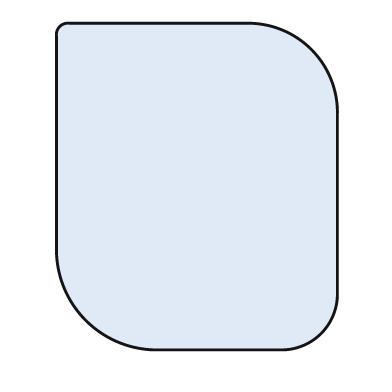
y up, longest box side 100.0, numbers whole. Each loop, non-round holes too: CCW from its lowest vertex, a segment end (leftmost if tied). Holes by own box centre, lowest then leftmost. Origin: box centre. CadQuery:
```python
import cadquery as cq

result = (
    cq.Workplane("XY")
    .moveTo(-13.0, -50.0)
    .lineTo(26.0, -50.0)
    .threePointArc((38.0, -45.0), (43.0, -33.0))
    .lineTo(43.0, 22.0)
    .threePointArc((35.0, 42.0), (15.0, 50.0))
    .lineTo(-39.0, 50.0)
    .threePointArc((-42.0, 49.0), (-43.0, 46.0))
    .lineTo(-43.0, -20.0)
    .threePointArc((-34.0, -41.0), (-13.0, -50.0))
    .close()
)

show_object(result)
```